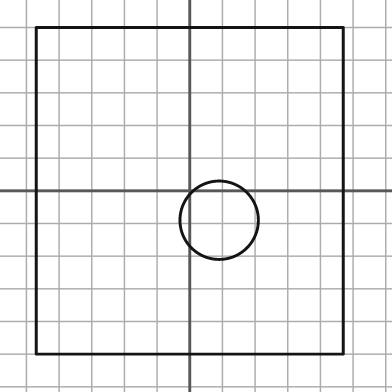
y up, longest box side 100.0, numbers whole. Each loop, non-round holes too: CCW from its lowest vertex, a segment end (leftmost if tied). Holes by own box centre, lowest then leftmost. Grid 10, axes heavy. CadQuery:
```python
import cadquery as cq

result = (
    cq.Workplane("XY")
    .moveTo(-47.0, -50.0)
    .lineTo(47.0, -50.0)
    .lineTo(47.0, 50.0)
    .lineTo(-47.0, 50.0)
    .close()
    .moveTo(9.0, -9.0)
    .circle(12.0)
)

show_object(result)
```